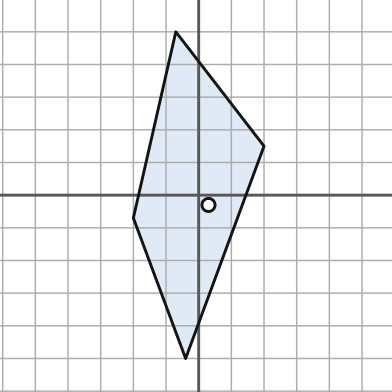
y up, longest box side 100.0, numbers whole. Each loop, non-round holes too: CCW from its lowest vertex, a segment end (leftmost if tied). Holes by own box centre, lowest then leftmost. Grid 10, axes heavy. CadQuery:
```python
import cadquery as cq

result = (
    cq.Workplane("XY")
    .moveTo(-4.0, -50.0)
    .lineTo(20.0, 15.0)
    .lineTo(-7.0, 50.0)
    .lineTo(-20.0, -7.0)
    .close()
    .moveTo(3.0, -3.0)
    .circle(2.0)
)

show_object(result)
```